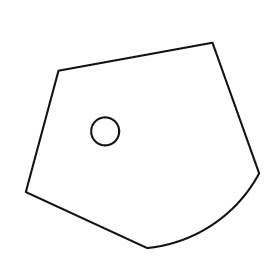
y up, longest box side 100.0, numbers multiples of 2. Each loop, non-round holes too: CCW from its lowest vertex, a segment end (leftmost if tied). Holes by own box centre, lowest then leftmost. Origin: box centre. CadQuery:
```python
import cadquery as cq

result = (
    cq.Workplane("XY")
    .moveTo(2.0, -44.0)
    .threePointArc((30.0, -34.0), (50.0, -12.0))
    .lineTo(30.0, 44.0)
    .lineTo(-36.0, 32.0)
    .lineTo(-50.0, -20.0)
    .close()
    .moveTo(-16.0, 6.0)
    .circle(6.0)
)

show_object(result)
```